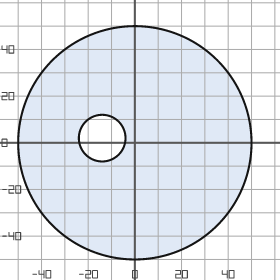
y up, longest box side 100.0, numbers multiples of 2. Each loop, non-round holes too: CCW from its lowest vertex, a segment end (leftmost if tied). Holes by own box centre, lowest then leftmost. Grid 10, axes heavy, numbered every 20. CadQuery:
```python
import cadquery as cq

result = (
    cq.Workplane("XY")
    .moveTo(0.0, 0.0)
    .circle(50.0)
    .moveTo(-14.0, 2.0)
    .circle(10.0)
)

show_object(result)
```